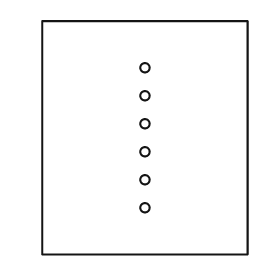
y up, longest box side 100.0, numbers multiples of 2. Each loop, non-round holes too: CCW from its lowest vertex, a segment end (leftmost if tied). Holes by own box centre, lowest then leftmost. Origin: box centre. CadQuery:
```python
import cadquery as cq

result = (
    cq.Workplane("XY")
    .moveTo(-44.0, -50.0)
    .lineTo(44.0, -50.0)
    .lineTo(44.0, 50.0)
    .lineTo(-44.0, 50.0)
    .close()
    .moveTo(0.0, -30.0)
    .circle(2.0)
    .moveTo(0.0, -18.0)
    .circle(2.0)
    .moveTo(0.0, -6.0)
    .circle(2.0)
    .moveTo(0.0, 6.0)
    .circle(2.0)
    .moveTo(0.0, 18.0)
    .circle(2.0)
    .moveTo(0.0, 30.0)
    .circle(2.0)
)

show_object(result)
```